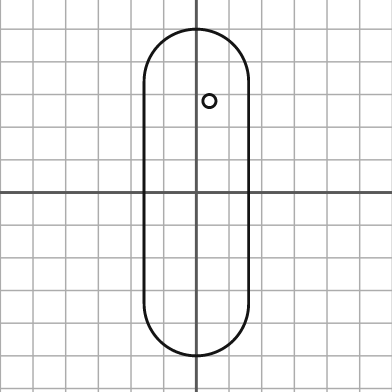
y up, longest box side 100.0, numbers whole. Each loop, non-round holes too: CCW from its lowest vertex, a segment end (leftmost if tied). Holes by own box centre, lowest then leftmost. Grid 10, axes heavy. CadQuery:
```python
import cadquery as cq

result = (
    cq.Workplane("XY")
    .moveTo(-16.0, -34.0)
    .threePointArc((0.0, -50.0), (16.0, -34.0))
    .lineTo(16.0, 34.0)
    .threePointArc((0.0, 50.0), (-16.0, 34.0))
    .close()
    .moveTo(4.0, 28.0)
    .circle(2.0)
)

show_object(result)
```